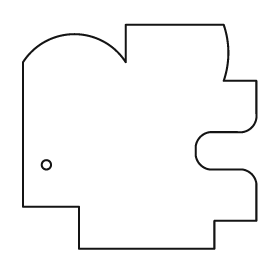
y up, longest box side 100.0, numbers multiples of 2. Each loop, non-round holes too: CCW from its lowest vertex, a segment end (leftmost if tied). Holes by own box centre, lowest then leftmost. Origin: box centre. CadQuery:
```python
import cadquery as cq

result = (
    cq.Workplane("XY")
    .moveTo(-26.0, -48.0)
    .lineTo(32.0, -48.0)
    .lineTo(32.0, -36.0)
    .lineTo(50.0, -36.0)
    .lineTo(50.0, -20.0)
    .threePointArc((48.0, -16.0), (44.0, -14.0))
    .lineTo(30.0, -14.0)
    .threePointArc((26.0, -12.0), (24.0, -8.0))
    .lineTo(24.0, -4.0)
    .threePointArc((26.0, 0.0), (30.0, 2.0))
    .lineTo(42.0, 2.0)
    .threePointArc((48.0, 4.0), (50.0, 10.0))
    .lineTo(50.0, 24.0)
    .lineTo(36.0, 24.0)
    .threePointArc((38.0, 36.0), (36.0, 48.0))
    .lineTo(-6.0, 48.0)
    .lineTo(-6.0, 32.0)
    .threePointArc((-28.0, 44.0), (-50.0, 32.0))
    .lineTo(-50.0, -30.0)
    .lineTo(-26.0, -30.0)
    .close()
    .moveTo(-40.0, -12.0)
    .circle(2.0)
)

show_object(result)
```